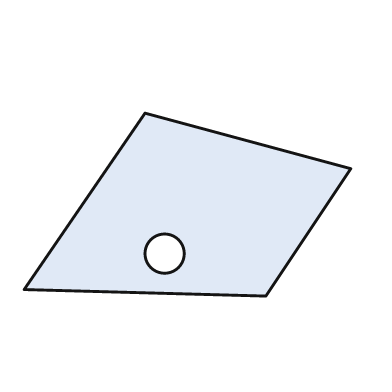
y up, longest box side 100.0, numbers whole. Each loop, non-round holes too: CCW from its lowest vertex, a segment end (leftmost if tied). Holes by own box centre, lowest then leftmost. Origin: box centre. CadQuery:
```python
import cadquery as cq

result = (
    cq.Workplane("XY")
    .moveTo(24.0, -28.0)
    .lineTo(50.0, 11.0)
    .lineTo(-13.0, 28.0)
    .lineTo(-50.0, -26.0)
    .close()
    .moveTo(-7.0, -15.0)
    .circle(6.0)
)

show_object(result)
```